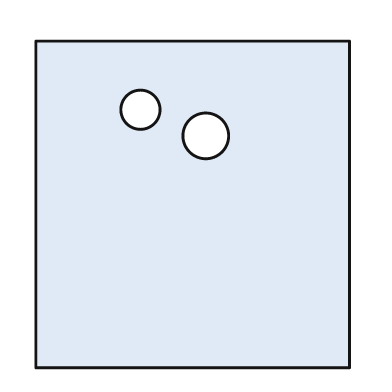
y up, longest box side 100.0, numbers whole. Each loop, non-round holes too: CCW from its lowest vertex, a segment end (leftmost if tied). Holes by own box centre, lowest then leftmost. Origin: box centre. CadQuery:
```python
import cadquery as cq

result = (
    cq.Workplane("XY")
    .moveTo(-48.0, -50.0)
    .lineTo(48.0, -50.0)
    .lineTo(48.0, 50.0)
    .lineTo(-48.0, 50.0)
    .close()
    .moveTo(4.0, 21.0)
    .circle(7.0)
    .moveTo(-16.0, 29.0)
    .circle(6.0)
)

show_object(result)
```